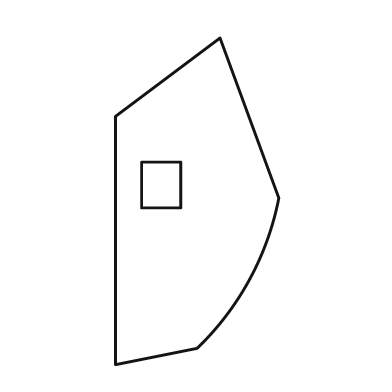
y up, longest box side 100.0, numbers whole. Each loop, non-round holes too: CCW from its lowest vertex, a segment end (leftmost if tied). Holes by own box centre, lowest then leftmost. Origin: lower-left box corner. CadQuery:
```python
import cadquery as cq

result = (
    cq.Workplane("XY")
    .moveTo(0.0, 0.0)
    .lineTo(25.0, 5.0)
    .threePointArc((41.0, 26.0), (50.0, 51.0))
    .lineTo(32.0, 100.0)
    .lineTo(0.0, 76.0)
    .close()
    .moveTo(8.0, 48.0)
    .lineTo(20.0, 48.0)
    .lineTo(20.0, 62.0)
    .lineTo(8.0, 62.0)
    .close()
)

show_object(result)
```